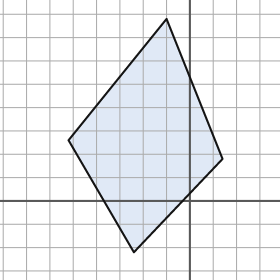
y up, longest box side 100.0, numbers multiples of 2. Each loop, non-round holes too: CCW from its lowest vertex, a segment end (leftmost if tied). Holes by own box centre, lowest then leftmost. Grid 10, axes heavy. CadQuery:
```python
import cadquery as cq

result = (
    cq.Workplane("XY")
    .moveTo(-24.0, -22.0)
    .lineTo(14.0, 18.0)
    .lineTo(-10.0, 78.0)
    .lineTo(-52.0, 26.0)
    .close()
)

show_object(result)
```